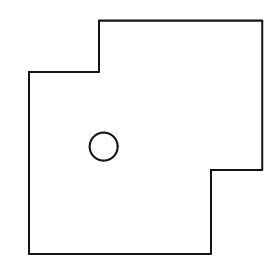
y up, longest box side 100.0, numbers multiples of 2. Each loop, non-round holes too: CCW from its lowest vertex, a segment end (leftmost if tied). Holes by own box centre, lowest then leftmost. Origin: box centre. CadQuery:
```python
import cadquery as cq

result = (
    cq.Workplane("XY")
    .moveTo(-50.0, -50.0)
    .lineTo(28.0, -50.0)
    .lineTo(28.0, -14.0)
    .lineTo(50.0, -14.0)
    .lineTo(50.0, 50.0)
    .lineTo(-20.0, 50.0)
    .lineTo(-20.0, 28.0)
    .lineTo(-50.0, 28.0)
    .close()
    .moveTo(-18.0, -4.0)
    .circle(6.0)
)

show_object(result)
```